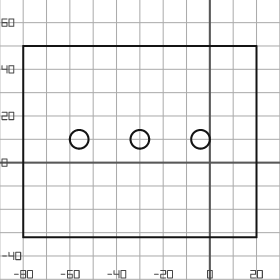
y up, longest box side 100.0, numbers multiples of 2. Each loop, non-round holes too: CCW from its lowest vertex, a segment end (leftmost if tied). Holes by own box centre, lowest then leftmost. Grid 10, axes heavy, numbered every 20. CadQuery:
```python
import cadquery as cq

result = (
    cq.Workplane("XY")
    .moveTo(-80.0, -32.0)
    .lineTo(20.0, -32.0)
    .lineTo(20.0, 50.0)
    .lineTo(-80.0, 50.0)
    .close()
    .moveTo(-56.0, 10.0)
    .circle(4.0)
    .moveTo(-30.0, 10.0)
    .circle(4.0)
    .moveTo(-4.0, 10.0)
    .circle(4.0)
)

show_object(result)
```